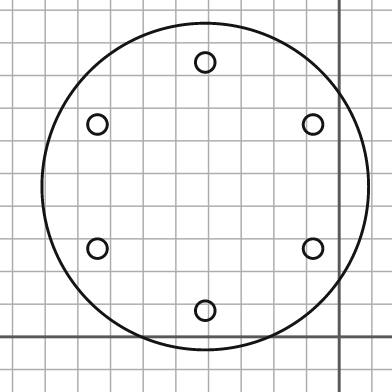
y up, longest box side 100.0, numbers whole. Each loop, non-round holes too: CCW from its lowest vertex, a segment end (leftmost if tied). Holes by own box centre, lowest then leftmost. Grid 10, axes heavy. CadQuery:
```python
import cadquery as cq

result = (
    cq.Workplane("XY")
    .moveTo(-41.0, 46.0)
    .circle(50.0)
    .moveTo(-41.0, 8.0)
    .circle(3.0)
    .moveTo(-74.0, 27.0)
    .circle(3.0)
    .moveTo(-8.0, 27.0)
    .circle(3.0)
    .moveTo(-74.0, 65.0)
    .circle(3.0)
    .moveTo(-8.0, 65.0)
    .circle(3.0)
    .moveTo(-41.0, 84.0)
    .circle(3.0)
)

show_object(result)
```